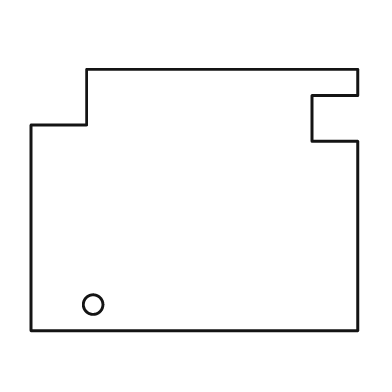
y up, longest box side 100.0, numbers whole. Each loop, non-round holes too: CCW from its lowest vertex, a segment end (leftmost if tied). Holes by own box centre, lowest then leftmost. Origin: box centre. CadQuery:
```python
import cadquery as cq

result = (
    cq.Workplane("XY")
    .moveTo(-50.0, -40.0)
    .lineTo(50.0, -40.0)
    .lineTo(50.0, 18.0)
    .lineTo(36.0, 18.0)
    .lineTo(36.0, 32.0)
    .lineTo(50.0, 32.0)
    .lineTo(50.0, 40.0)
    .lineTo(-33.0, 40.0)
    .lineTo(-33.0, 23.0)
    .lineTo(-50.0, 23.0)
    .close()
    .moveTo(-31.0, -32.0)
    .circle(3.0)
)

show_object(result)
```